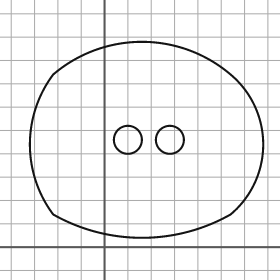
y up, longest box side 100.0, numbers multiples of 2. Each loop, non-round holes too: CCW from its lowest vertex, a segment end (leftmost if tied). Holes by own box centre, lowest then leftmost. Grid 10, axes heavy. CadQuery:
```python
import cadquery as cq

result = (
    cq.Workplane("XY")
    .moveTo(-22.0, 14.0)
    .threePointArc((16.0, 4.0), (54.0, 14.0))
    .threePointArc((68.0, 44.0), (54.0, 74.0))
    .threePointArc((16.0, 88.0), (-22.0, 74.0))
    .threePointArc((-32.0, 44.0), (-22.0, 14.0))
    .close()
    .moveTo(10.0, 46.0)
    .circle(6.0)
    .moveTo(28.0, 46.0)
    .circle(6.0)
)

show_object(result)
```